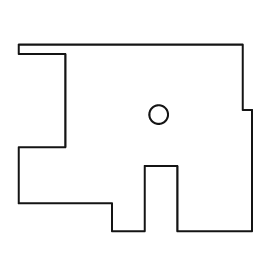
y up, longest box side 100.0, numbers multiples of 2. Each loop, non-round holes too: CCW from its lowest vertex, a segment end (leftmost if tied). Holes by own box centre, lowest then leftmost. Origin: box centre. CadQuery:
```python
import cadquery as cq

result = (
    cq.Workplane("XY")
    .moveTo(-10.0, -40.0)
    .lineTo(4.0, -40.0)
    .lineTo(4.0, -12.0)
    .lineTo(18.0, -12.0)
    .lineTo(18.0, -40.0)
    .lineTo(50.0, -40.0)
    .lineTo(50.0, 12.0)
    .lineTo(46.0, 12.0)
    .lineTo(46.0, 40.0)
    .lineTo(-50.0, 40.0)
    .lineTo(-50.0, 36.0)
    .lineTo(-30.0, 36.0)
    .lineTo(-30.0, -4.0)
    .lineTo(-50.0, -4.0)
    .lineTo(-50.0, -28.0)
    .lineTo(-10.0, -28.0)
    .close()
    .moveTo(10.0, 10.0)
    .circle(4.0)
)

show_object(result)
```